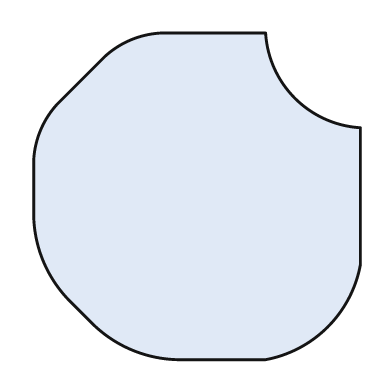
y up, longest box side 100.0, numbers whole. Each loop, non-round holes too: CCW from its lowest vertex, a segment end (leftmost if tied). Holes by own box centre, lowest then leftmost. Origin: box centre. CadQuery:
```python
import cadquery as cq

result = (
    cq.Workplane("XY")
    .moveTo(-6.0, -50.0)
    .lineTo(21.0, -50.0)
    .threePointArc((40.0, -40.0), (50.0, -21.0))
    .lineTo(50.0, 21.0)
    .threePointArc((30.0, 30.0), (21.0, 50.0))
    .lineTo(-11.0, 50.0)
    .threePointArc((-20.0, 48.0), (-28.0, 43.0))
    .lineTo(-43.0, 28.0)
    .threePointArc((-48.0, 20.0), (-50.0, 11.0))
    .lineTo(-50.0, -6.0)
    .threePointArc((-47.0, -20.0), (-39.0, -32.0))
    .lineTo(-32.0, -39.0)
    .threePointArc((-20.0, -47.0), (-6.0, -50.0))
    .close()
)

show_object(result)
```